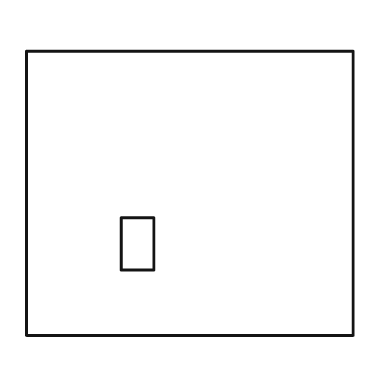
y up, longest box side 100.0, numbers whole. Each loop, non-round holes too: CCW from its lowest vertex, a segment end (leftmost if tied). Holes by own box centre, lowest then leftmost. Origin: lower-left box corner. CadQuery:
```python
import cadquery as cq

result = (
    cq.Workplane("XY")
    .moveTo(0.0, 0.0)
    .lineTo(100.0, 0.0)
    .lineTo(100.0, 87.0)
    .lineTo(0.0, 87.0)
    .close()
    .moveTo(29.0, 20.0)
    .lineTo(39.0, 20.0)
    .lineTo(39.0, 36.0)
    .lineTo(29.0, 36.0)
    .close()
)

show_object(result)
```